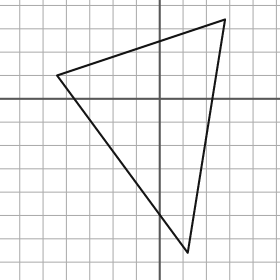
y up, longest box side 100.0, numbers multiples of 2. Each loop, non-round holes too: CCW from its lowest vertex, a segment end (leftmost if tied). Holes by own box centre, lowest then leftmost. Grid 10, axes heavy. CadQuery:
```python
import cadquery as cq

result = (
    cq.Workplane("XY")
    .moveTo(12.0, -66.0)
    .lineTo(28.0, 34.0)
    .lineTo(-44.0, 10.0)
    .close()
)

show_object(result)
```